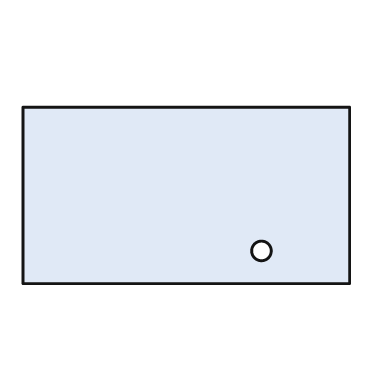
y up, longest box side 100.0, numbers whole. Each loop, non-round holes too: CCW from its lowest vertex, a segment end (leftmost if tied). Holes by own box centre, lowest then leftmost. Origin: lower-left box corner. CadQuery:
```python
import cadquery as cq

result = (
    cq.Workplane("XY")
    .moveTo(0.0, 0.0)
    .lineTo(100.0, 0.0)
    .lineTo(100.0, 54.0)
    .lineTo(0.0, 54.0)
    .close()
    .moveTo(73.0, 10.0)
    .circle(3.0)
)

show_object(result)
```